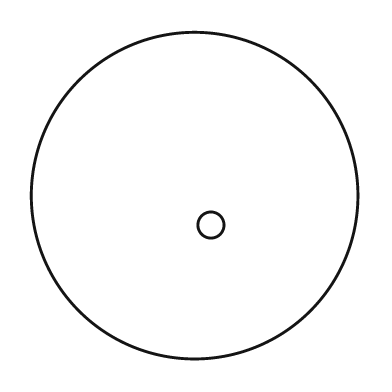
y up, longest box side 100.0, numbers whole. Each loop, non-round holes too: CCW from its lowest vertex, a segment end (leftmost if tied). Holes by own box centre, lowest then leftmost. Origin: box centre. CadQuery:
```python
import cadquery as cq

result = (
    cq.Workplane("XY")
    .moveTo(0.0, 0.0)
    .circle(50.0)
    .moveTo(5.0, -9.0)
    .circle(4.0)
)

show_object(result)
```